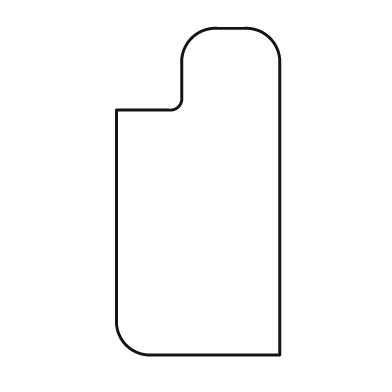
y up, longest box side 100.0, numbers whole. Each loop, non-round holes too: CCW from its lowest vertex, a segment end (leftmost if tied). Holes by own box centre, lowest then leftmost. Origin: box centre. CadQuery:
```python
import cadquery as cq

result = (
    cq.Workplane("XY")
    .moveTo(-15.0, -50.0)
    .lineTo(25.0, -50.0)
    .lineTo(25.0, 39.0)
    .threePointArc((22.0, 47.0), (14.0, 50.0))
    .lineTo(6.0, 50.0)
    .threePointArc((-2.0, 47.0), (-5.0, 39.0))
    .lineTo(-5.0, 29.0)
    .threePointArc((-6.0, 26.0), (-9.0, 25.0))
    .lineTo(-25.0, 25.0)
    .lineTo(-25.0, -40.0)
    .threePointArc((-22.0, -47.0), (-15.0, -50.0))
    .close()
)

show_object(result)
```